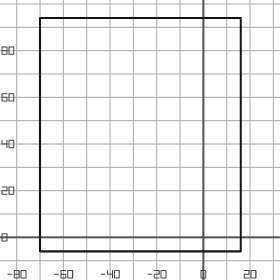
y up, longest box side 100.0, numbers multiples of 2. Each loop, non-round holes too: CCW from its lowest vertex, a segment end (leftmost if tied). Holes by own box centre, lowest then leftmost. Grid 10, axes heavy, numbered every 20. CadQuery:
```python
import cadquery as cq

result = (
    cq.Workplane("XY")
    .moveTo(-70.0, -6.0)
    .lineTo(16.0, -6.0)
    .lineTo(16.0, 94.0)
    .lineTo(-70.0, 94.0)
    .close()
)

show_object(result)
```